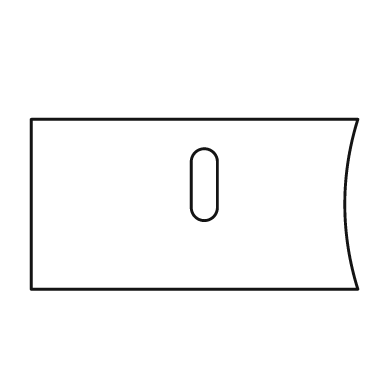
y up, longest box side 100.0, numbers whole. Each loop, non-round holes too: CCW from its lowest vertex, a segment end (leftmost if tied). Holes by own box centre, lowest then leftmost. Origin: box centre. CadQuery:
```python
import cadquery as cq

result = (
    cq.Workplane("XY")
    .moveTo(-50.0, -26.0)
    .lineTo(50.0, -26.0)
    .threePointArc((46.0, 0.0), (50.0, 26.0))
    .lineTo(-50.0, 26.0)
    .close()
    .moveTo(-1.0, -1.0)
    .threePointArc((3.0, -5.0), (7.0, -1.0))
    .lineTo(7.0, 13.0)
    .threePointArc((3.0, 17.0), (-1.0, 13.0))
    .close()
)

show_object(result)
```